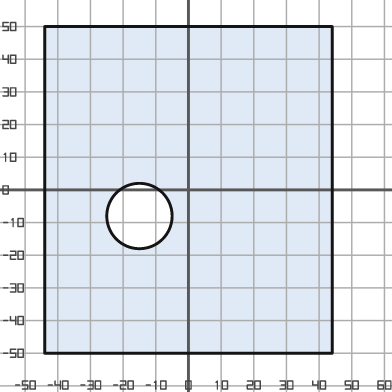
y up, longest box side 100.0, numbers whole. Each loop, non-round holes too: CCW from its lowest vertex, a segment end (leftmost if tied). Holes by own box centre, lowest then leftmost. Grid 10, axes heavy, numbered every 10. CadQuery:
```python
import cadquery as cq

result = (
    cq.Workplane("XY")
    .moveTo(-44.0, -50.0)
    .lineTo(44.0, -50.0)
    .lineTo(44.0, 50.0)
    .lineTo(-44.0, 50.0)
    .close()
    .moveTo(-15.0, -8.0)
    .circle(10.0)
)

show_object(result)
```